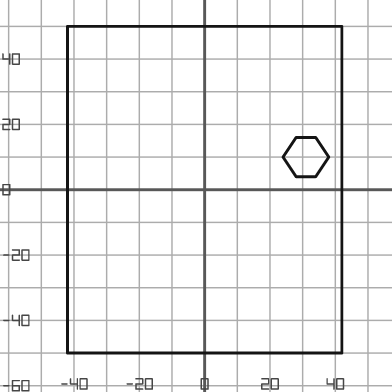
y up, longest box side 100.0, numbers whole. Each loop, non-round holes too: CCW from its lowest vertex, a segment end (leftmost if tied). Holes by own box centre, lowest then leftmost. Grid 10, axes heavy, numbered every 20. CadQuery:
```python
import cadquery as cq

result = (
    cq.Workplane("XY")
    .moveTo(-42.0, -50.0)
    .lineTo(42.0, -50.0)
    .lineTo(42.0, 50.0)
    .lineTo(-42.0, 50.0)
    .close()
    .moveTo(28.0, 4.0)
    .lineTo(34.0, 4.0)
    .lineTo(38.0, 10.0)
    .lineTo(34.0, 16.0)
    .lineTo(28.0, 16.0)
    .lineTo(24.0, 10.0)
    .close()
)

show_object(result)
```